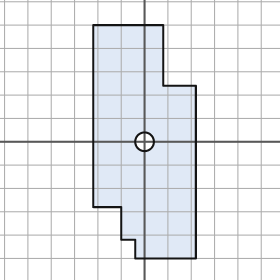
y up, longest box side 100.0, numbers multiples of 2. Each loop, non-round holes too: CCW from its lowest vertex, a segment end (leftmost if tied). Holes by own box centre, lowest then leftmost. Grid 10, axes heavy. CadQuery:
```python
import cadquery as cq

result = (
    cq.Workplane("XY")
    .moveTo(-4.0, -50.0)
    .lineTo(22.0, -50.0)
    .lineTo(22.0, 24.0)
    .lineTo(8.0, 24.0)
    .lineTo(8.0, 50.0)
    .lineTo(-22.0, 50.0)
    .lineTo(-22.0, -28.0)
    .lineTo(-10.0, -28.0)
    .lineTo(-10.0, -42.0)
    .lineTo(-4.0, -42.0)
    .close()
    .moveTo(0.0, 0.0)
    .circle(4.0)
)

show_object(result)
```